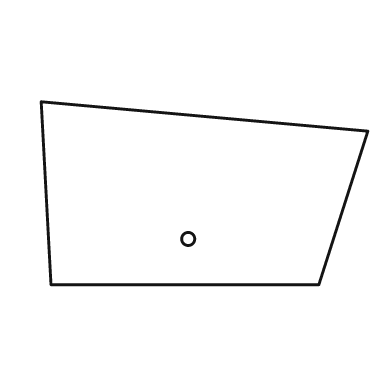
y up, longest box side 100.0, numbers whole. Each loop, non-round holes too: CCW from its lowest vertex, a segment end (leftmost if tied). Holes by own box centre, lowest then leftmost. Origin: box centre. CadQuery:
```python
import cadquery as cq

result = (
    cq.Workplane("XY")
    .moveTo(-47.0, -28.0)
    .lineTo(35.0, -28.0)
    .lineTo(50.0, 19.0)
    .lineTo(-50.0, 28.0)
    .close()
    .moveTo(-5.0, -14.0)
    .circle(2.0)
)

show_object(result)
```